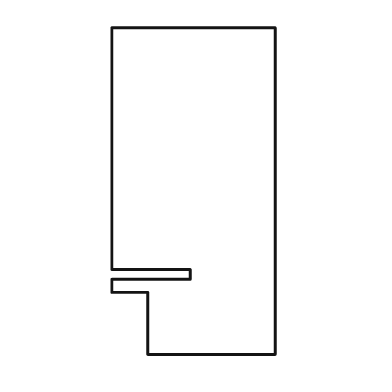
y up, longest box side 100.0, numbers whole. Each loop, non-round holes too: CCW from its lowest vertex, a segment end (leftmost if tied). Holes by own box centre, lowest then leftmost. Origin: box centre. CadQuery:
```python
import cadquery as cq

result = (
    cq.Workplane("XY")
    .moveTo(-14.0, -50.0)
    .lineTo(25.0, -50.0)
    .lineTo(25.0, 50.0)
    .lineTo(-25.0, 50.0)
    .lineTo(-25.0, -24.0)
    .lineTo(-1.0, -24.0)
    .lineTo(-1.0, -27.0)
    .lineTo(-25.0, -27.0)
    .lineTo(-25.0, -31.0)
    .lineTo(-14.0, -31.0)
    .close()
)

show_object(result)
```